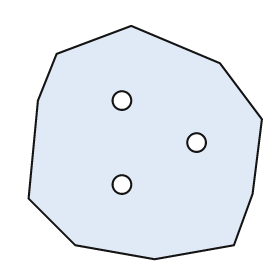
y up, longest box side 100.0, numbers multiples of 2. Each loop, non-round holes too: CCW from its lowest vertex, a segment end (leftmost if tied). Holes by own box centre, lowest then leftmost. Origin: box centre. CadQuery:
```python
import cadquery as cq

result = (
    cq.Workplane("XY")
    .moveTo(4.0, -50.0)
    .lineTo(38.0, -44.0)
    .lineTo(46.0, -22.0)
    .lineTo(50.0, 10.0)
    .lineTo(32.0, 34.0)
    .lineTo(-6.0, 50.0)
    .lineTo(-38.0, 38.0)
    .lineTo(-46.0, 18.0)
    .lineTo(-50.0, -24.0)
    .lineTo(-30.0, -44.0)
    .close()
    .moveTo(-10.0, -18.0)
    .circle(4.0)
    .moveTo(22.0, 0.0)
    .circle(4.0)
    .moveTo(-10.0, 18.0)
    .circle(4.0)
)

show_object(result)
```